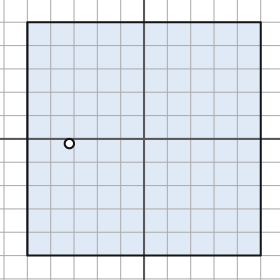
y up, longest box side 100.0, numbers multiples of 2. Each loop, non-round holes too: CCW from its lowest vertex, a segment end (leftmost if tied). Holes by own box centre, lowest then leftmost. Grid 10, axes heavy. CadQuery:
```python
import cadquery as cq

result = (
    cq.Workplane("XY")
    .moveTo(-50.0, -50.0)
    .lineTo(50.0, -50.0)
    .lineTo(50.0, 50.0)
    .lineTo(-50.0, 50.0)
    .close()
    .moveTo(-32.0, -2.0)
    .circle(2.0)
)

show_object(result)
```